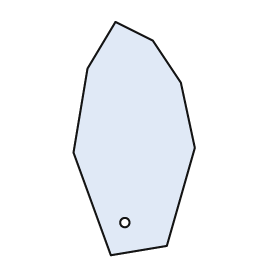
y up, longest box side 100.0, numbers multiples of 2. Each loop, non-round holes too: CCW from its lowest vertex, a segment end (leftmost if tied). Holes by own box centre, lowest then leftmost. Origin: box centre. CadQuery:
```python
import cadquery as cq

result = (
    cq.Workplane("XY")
    .moveTo(-10.0, -50.0)
    .lineTo(14.0, -46.0)
    .lineTo(26.0, -4.0)
    .lineTo(20.0, 24.0)
    .lineTo(8.0, 42.0)
    .lineTo(-8.0, 50.0)
    .lineTo(-20.0, 30.0)
    .lineTo(-26.0, -6.0)
    .close()
    .moveTo(-4.0, -36.0)
    .circle(2.0)
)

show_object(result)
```